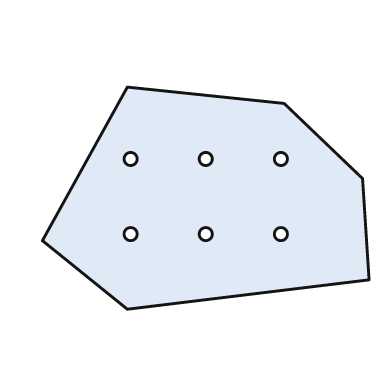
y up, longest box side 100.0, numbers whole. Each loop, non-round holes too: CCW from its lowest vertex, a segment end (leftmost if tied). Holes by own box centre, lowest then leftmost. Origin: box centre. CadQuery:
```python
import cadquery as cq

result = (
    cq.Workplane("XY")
    .moveTo(-24.0, -34.0)
    .lineTo(50.0, -25.0)
    .lineTo(48.0, 6.0)
    .lineTo(24.0, 29.0)
    .lineTo(-24.0, 34.0)
    .lineTo(-50.0, -13.0)
    .close()
    .moveTo(-23.0, -11.0)
    .circle(2.0)
    .moveTo(0.0, -11.0)
    .circle(2.0)
    .moveTo(23.0, -11.0)
    .circle(2.0)
    .moveTo(-23.0, 12.0)
    .circle(2.0)
    .moveTo(0.0, 12.0)
    .circle(2.0)
    .moveTo(23.0, 12.0)
    .circle(2.0)
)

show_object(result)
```